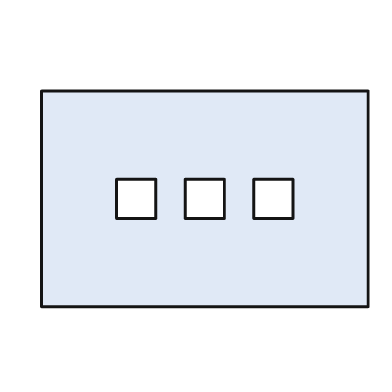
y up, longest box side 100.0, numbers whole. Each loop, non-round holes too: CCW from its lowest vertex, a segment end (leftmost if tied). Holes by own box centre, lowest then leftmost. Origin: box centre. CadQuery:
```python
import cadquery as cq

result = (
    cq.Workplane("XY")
    .moveTo(-50.0, -33.0)
    .lineTo(50.0, -33.0)
    .lineTo(50.0, 33.0)
    .lineTo(-50.0, 33.0)
    .close()
    .moveTo(-27.0, -6.0)
    .lineTo(-15.0, -6.0)
    .lineTo(-15.0, 6.0)
    .lineTo(-27.0, 6.0)
    .close()
    .moveTo(-6.0, -6.0)
    .lineTo(6.0, -6.0)
    .lineTo(6.0, 6.0)
    .lineTo(-6.0, 6.0)
    .close()
    .moveTo(15.0, -6.0)
    .lineTo(27.0, -6.0)
    .lineTo(27.0, 6.0)
    .lineTo(15.0, 6.0)
    .close()
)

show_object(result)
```